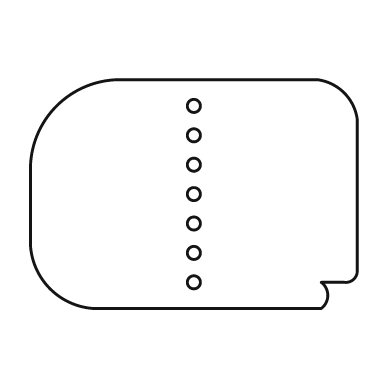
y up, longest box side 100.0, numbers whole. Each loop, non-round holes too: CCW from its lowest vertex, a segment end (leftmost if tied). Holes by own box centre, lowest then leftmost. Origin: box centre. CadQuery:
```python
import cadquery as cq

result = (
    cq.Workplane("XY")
    .moveTo(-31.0, -35.0)
    .lineTo(39.0, -35.0)
    .threePointArc((41.0, -31.0), (39.0, -27.0))
    .lineTo(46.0, -27.0)
    .threePointArc((49.0, -26.0), (50.0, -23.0))
    .lineTo(50.0, 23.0)
    .threePointArc((46.0, 31.0), (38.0, 35.0))
    .lineTo(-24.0, 35.0)
    .threePointArc((-42.0, 27.0), (-50.0, 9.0))
    .lineTo(-50.0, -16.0)
    .threePointArc((-44.0, -29.0), (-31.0, -35.0))
    .close()
    .moveTo(0.0, -27.0)
    .circle(2.0)
    .moveTo(0.0, -18.0)
    .circle(2.0)
    .moveTo(0.0, -9.0)
    .circle(2.0)
    .moveTo(0.0, 0.0)
    .circle(2.0)
    .moveTo(0.0, 9.0)
    .circle(2.0)
    .moveTo(0.0, 18.0)
    .circle(2.0)
    .moveTo(0.0, 27.0)
    .circle(2.0)
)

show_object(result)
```